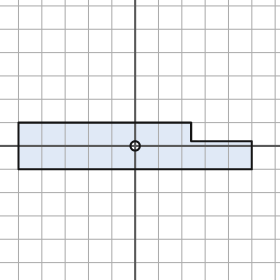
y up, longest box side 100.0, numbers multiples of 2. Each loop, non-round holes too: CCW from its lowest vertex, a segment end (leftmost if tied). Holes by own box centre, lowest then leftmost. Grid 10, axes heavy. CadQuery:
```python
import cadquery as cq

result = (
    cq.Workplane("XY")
    .moveTo(-50.0, -10.0)
    .lineTo(50.0, -10.0)
    .lineTo(50.0, 2.0)
    .lineTo(24.0, 2.0)
    .lineTo(24.0, 10.0)
    .lineTo(-50.0, 10.0)
    .close()
    .moveTo(0.0, 0.0)
    .circle(2.0)
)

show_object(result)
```